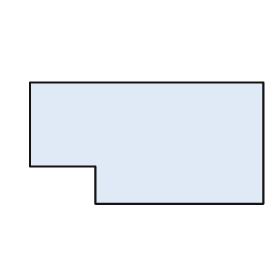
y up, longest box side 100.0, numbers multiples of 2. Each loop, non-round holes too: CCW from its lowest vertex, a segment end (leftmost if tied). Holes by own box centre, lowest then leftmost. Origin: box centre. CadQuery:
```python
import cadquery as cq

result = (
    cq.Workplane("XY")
    .moveTo(-22.0, -26.0)
    .lineTo(50.0, -26.0)
    .lineTo(50.0, 26.0)
    .lineTo(-50.0, 26.0)
    .lineTo(-50.0, -10.0)
    .lineTo(-22.0, -10.0)
    .close()
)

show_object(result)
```